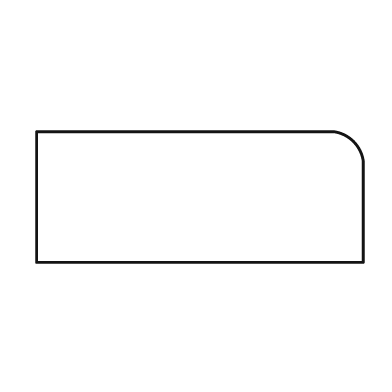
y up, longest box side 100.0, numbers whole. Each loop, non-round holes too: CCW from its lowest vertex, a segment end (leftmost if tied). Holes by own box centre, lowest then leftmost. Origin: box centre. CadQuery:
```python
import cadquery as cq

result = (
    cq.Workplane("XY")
    .moveTo(-50.0, -20.0)
    .lineTo(50.0, -20.0)
    .lineTo(50.0, 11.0)
    .threePointArc((47.0, 17.0), (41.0, 20.0))
    .lineTo(-50.0, 20.0)
    .close()
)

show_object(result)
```